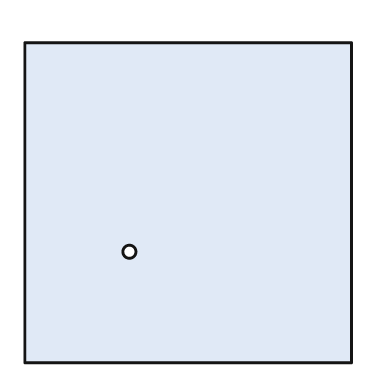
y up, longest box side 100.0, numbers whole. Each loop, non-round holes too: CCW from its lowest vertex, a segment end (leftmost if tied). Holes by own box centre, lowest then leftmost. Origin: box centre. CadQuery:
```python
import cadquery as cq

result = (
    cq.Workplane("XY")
    .moveTo(-50.0, -49.0)
    .lineTo(50.0, -49.0)
    .lineTo(50.0, 49.0)
    .lineTo(-50.0, 49.0)
    .close()
    .moveTo(-18.0, -15.0)
    .circle(2.0)
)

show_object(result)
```